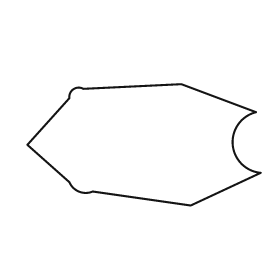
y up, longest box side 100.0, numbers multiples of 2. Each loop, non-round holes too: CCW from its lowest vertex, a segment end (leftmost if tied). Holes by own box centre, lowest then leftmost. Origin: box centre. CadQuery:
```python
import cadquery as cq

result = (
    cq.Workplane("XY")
    .moveTo(20.0, -26.0)
    .lineTo(50.0, -12.0)
    .threePointArc((38.0, 0.0), (48.0, 14.0))
    .lineTo(16.0, 26.0)
    .lineTo(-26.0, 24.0)
    .threePointArc((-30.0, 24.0), (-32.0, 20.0))
    .lineTo(-50.0, 0.0)
    .lineTo(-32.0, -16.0)
    .threePointArc((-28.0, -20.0), (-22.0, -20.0))
    .close()
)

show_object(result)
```